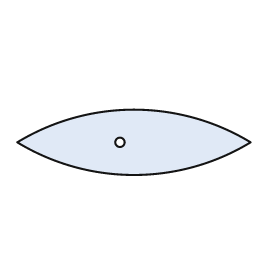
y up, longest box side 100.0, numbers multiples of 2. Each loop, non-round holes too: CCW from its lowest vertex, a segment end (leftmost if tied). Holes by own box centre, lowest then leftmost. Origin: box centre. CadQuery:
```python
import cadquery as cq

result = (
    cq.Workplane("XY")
    .moveTo(-50.0, 0.0)
    .threePointArc((0.0, -14.0), (50.0, 0.0))
    .threePointArc((0.0, 14.0), (-50.0, 0.0))
    .close()
    .moveTo(-6.0, 0.0)
    .circle(2.0)
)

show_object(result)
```